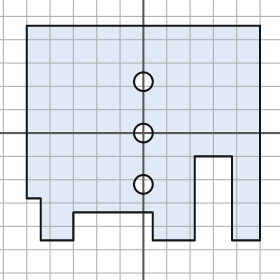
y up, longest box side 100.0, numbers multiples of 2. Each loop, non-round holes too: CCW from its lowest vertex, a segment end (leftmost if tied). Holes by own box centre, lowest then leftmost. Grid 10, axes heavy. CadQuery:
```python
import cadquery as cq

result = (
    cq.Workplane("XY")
    .moveTo(-44.0, -46.0)
    .lineTo(-30.0, -46.0)
    .lineTo(-30.0, -34.0)
    .lineTo(4.0, -34.0)
    .lineTo(4.0, -46.0)
    .lineTo(22.0, -46.0)
    .lineTo(22.0, -10.0)
    .lineTo(38.0, -10.0)
    .lineTo(38.0, -46.0)
    .lineTo(50.0, -46.0)
    .lineTo(50.0, 46.0)
    .lineTo(-50.0, 46.0)
    .lineTo(-50.0, -28.0)
    .lineTo(-44.0, -28.0)
    .close()
    .moveTo(0.0, -22.0)
    .circle(4.0)
    .moveTo(0.0, 0.0)
    .circle(4.0)
    .moveTo(0.0, 22.0)
    .circle(4.0)
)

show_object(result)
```